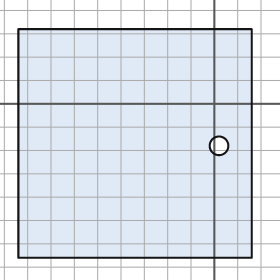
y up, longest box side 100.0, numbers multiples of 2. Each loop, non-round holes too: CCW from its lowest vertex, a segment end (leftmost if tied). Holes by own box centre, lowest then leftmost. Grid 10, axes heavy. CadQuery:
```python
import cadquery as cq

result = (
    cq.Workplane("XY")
    .moveTo(-84.0, -66.0)
    .lineTo(16.0, -66.0)
    .lineTo(16.0, 32.0)
    .lineTo(-84.0, 32.0)
    .close()
    .moveTo(2.0, -18.0)
    .circle(4.0)
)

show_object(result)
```